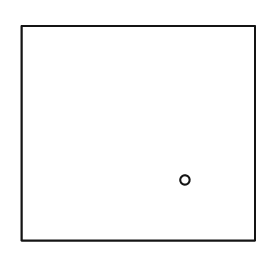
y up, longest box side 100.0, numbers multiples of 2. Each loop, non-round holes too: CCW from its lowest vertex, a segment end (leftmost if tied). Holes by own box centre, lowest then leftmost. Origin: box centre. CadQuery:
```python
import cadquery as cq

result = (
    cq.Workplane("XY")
    .moveTo(-50.0, -46.0)
    .lineTo(50.0, -46.0)
    .lineTo(50.0, 46.0)
    .lineTo(-50.0, 46.0)
    .close()
    .moveTo(20.0, -20.0)
    .circle(2.0)
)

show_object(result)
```